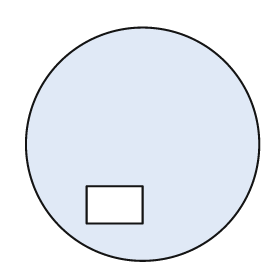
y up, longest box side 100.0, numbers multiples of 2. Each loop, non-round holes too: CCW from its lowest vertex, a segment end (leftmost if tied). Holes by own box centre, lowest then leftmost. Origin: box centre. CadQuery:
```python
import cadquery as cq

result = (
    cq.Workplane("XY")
    .moveTo(0.0, 0.0)
    .circle(50.0)
    .moveTo(-24.0, -34.0)
    .lineTo(0.0, -34.0)
    .lineTo(0.0, -18.0)
    .lineTo(-24.0, -18.0)
    .close()
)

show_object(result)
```